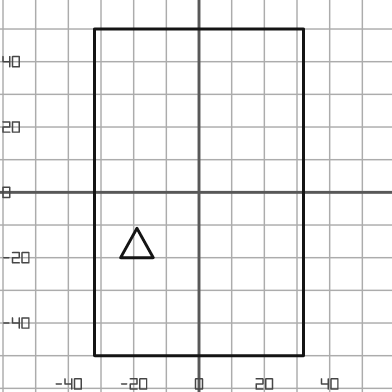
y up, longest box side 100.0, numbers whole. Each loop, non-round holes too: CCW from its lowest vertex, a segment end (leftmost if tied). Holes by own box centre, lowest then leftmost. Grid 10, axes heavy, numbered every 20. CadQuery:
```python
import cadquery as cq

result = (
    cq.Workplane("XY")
    .moveTo(-32.0, -50.0)
    .lineTo(32.0, -50.0)
    .lineTo(32.0, 50.0)
    .lineTo(-32.0, 50.0)
    .close()
    .moveTo(-24.0, -20.0)
    .lineTo(-14.0, -20.0)
    .lineTo(-19.0, -11.0)
    .close()
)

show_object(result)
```